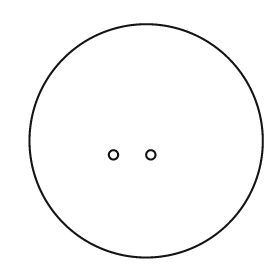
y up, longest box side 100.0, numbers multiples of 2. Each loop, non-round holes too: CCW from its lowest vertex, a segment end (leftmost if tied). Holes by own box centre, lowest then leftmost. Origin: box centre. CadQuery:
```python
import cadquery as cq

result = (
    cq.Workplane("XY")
    .moveTo(0.0, 0.0)
    .circle(50.0)
    .moveTo(-14.0, -6.0)
    .circle(2.0)
    .moveTo(2.0, -6.0)
    .circle(2.0)
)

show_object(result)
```